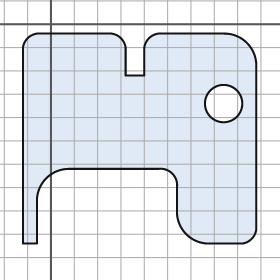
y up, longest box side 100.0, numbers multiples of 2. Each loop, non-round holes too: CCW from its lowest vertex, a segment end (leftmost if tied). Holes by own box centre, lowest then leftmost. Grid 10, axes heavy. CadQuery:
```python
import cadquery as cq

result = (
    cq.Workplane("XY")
    .moveTo(-12.0, -94.0)
    .lineTo(-6.0, -94.0)
    .lineTo(-6.0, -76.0)
    .threePointArc((-2.0, -66.0), (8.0, -62.0))
    .lineTo(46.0, -62.0)
    .threePointArc((52.0, -64.0), (54.0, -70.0))
    .lineTo(54.0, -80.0)
    .threePointArc((58.0, -90.0), (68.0, -94.0))
    .lineTo(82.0, -94.0)
    .threePointArc((86.0, -92.0), (88.0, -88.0))
    .lineTo(88.0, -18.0)
    .threePointArc((84.0, -8.0), (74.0, -4.0))
    .lineTo(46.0, -4.0)
    .threePointArc((42.0, -6.0), (40.0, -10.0))
    .lineTo(40.0, -22.0)
    .lineTo(32.0, -22.0)
    .lineTo(32.0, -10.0)
    .threePointArc((30.0, -6.0), (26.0, -4.0))
    .lineTo(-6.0, -4.0)
    .threePointArc((-10.0, -6.0), (-12.0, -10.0))
    .close()
    .moveTo(74.0, -34.0)
    .circle(8.0)
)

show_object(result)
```